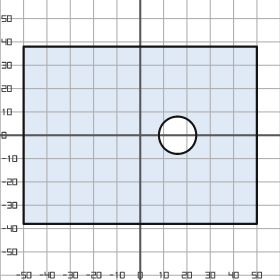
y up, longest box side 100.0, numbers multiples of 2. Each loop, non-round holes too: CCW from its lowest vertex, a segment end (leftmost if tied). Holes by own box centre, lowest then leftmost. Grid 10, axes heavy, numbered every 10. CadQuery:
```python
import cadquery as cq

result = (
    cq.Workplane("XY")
    .moveTo(-50.0, -38.0)
    .lineTo(50.0, -38.0)
    .lineTo(50.0, 38.0)
    .lineTo(-50.0, 38.0)
    .close()
    .moveTo(16.0, 0.0)
    .circle(8.0)
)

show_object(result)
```